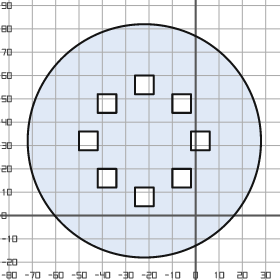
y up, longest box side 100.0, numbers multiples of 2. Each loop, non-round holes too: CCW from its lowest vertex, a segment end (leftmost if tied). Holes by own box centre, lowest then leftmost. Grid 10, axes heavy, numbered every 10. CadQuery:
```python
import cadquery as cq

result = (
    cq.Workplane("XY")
    .moveTo(-22.0, 32.0)
    .circle(50.0)
    .moveTo(-26.0, 4.0)
    .lineTo(-18.0, 4.0)
    .lineTo(-18.0, 12.0)
    .lineTo(-26.0, 12.0)
    .close()
    .moveTo(-42.0, 12.0)
    .lineTo(-34.0, 12.0)
    .lineTo(-34.0, 20.0)
    .lineTo(-42.0, 20.0)
    .close()
    .moveTo(-10.0, 12.0)
    .lineTo(-2.0, 12.0)
    .lineTo(-2.0, 20.0)
    .lineTo(-10.0, 20.0)
    .close()
    .moveTo(-50.0, 28.0)
    .lineTo(-42.0, 28.0)
    .lineTo(-42.0, 36.0)
    .lineTo(-50.0, 36.0)
    .close()
    .moveTo(-2.0, 28.0)
    .lineTo(6.0, 28.0)
    .lineTo(6.0, 36.0)
    .lineTo(-2.0, 36.0)
    .close()
    .moveTo(-42.0, 44.0)
    .lineTo(-34.0, 44.0)
    .lineTo(-34.0, 52.0)
    .lineTo(-42.0, 52.0)
    .close()
    .moveTo(-10.0, 44.0)
    .lineTo(-2.0, 44.0)
    .lineTo(-2.0, 52.0)
    .lineTo(-10.0, 52.0)
    .close()
    .moveTo(-26.0, 52.0)
    .lineTo(-18.0, 52.0)
    .lineTo(-18.0, 60.0)
    .lineTo(-26.0, 60.0)
    .close()
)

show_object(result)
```